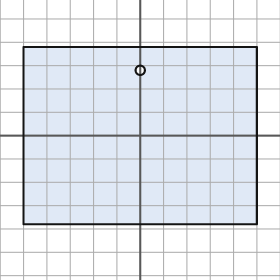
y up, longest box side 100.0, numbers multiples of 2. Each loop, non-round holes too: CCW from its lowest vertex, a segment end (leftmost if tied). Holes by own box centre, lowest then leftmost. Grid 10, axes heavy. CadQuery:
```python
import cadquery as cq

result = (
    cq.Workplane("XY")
    .moveTo(-50.0, -38.0)
    .lineTo(50.0, -38.0)
    .lineTo(50.0, 38.0)
    .lineTo(-50.0, 38.0)
    .close()
    .moveTo(0.0, 28.0)
    .circle(2.0)
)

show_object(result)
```